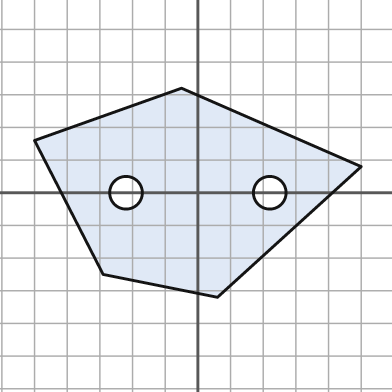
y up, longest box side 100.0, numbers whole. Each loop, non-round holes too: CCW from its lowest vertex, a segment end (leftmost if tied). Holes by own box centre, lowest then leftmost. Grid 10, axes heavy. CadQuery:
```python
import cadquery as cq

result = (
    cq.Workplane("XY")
    .moveTo(6.0, -32.0)
    .lineTo(50.0, 8.0)
    .lineTo(-5.0, 32.0)
    .lineTo(-50.0, 16.0)
    .lineTo(-29.0, -25.0)
    .close()
    .moveTo(-22.0, 0.0)
    .circle(5.0)
    .moveTo(22.0, 0.0)
    .circle(5.0)
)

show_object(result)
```